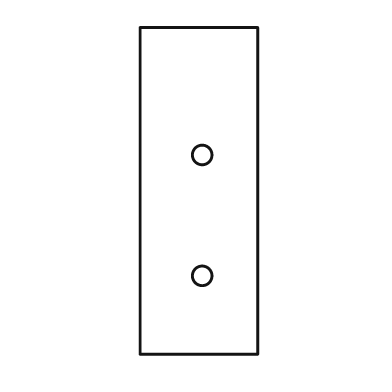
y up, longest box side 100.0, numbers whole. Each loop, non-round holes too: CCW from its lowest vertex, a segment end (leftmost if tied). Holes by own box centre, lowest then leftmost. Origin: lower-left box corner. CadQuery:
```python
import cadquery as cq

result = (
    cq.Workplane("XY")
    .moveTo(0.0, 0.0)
    .lineTo(36.0, 0.0)
    .lineTo(36.0, 100.0)
    .lineTo(0.0, 100.0)
    .close()
    .moveTo(19.0, 24.0)
    .circle(3.0)
    .moveTo(19.0, 61.0)
    .circle(3.0)
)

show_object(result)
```